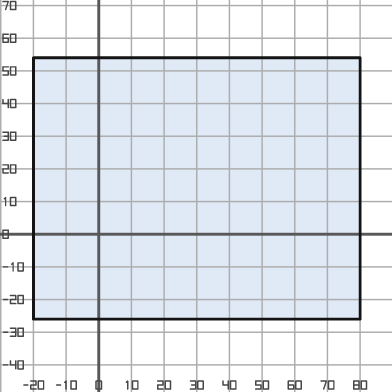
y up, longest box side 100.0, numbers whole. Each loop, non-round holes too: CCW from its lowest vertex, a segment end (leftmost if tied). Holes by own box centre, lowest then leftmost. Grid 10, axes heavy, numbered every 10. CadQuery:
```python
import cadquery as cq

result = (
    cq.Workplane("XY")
    .moveTo(-20.0, -26.0)
    .lineTo(80.0, -26.0)
    .lineTo(80.0, 54.0)
    .lineTo(-20.0, 54.0)
    .close()
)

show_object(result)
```